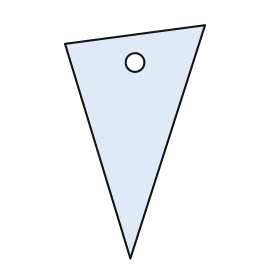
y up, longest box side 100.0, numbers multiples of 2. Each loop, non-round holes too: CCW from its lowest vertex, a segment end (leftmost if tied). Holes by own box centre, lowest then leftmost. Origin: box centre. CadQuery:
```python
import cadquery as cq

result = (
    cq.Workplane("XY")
    .moveTo(-2.0, -50.0)
    .lineTo(30.0, 50.0)
    .lineTo(-30.0, 42.0)
    .close()
    .moveTo(0.0, 34.0)
    .circle(4.0)
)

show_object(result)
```